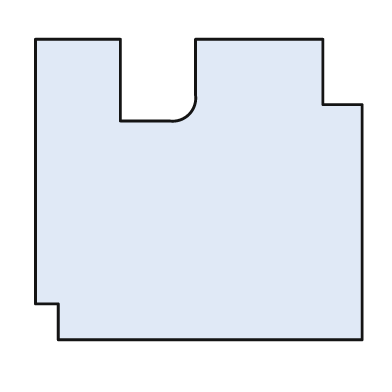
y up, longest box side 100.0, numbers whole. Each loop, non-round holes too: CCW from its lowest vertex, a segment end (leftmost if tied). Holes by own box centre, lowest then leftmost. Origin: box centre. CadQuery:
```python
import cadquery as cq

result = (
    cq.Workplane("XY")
    .moveTo(-43.0, -46.0)
    .lineTo(50.0, -46.0)
    .lineTo(50.0, 26.0)
    .lineTo(38.0, 26.0)
    .lineTo(38.0, 46.0)
    .lineTo(-1.0, 46.0)
    .lineTo(-1.0, 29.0)
    .threePointArc((-3.0, 23.0), (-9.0, 21.0))
    .lineTo(-24.0, 21.0)
    .lineTo(-24.0, 46.0)
    .lineTo(-50.0, 46.0)
    .lineTo(-50.0, -35.0)
    .lineTo(-43.0, -35.0)
    .close()
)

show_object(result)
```